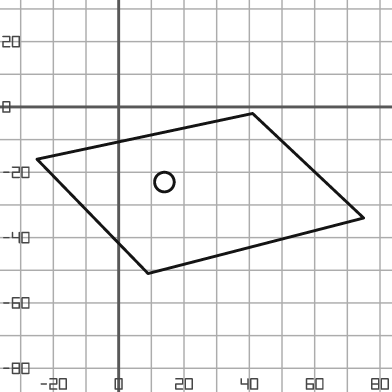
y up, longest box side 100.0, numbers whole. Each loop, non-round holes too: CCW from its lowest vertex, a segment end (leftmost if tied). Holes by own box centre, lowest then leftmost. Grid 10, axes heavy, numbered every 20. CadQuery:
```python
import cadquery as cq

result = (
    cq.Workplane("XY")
    .moveTo(9.0, -51.0)
    .lineTo(75.0, -34.0)
    .lineTo(41.0, -2.0)
    .lineTo(-25.0, -16.0)
    .close()
    .moveTo(14.0, -23.0)
    .circle(3.0)
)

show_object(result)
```